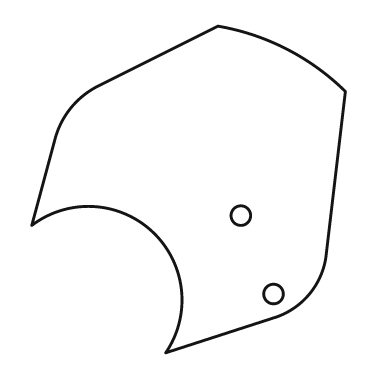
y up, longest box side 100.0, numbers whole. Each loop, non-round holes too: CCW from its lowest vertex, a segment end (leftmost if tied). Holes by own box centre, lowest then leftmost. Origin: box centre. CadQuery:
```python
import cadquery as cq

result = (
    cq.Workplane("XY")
    .moveTo(-7.0, -50.0)
    .lineTo(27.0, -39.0)
    .threePointArc((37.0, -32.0), (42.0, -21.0))
    .lineTo(48.0, 30.0)
    .threePointArc((30.0, 43.0), (9.0, 50.0))
    .lineTo(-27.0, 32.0)
    .threePointArc((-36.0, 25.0), (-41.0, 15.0))
    .lineTo(-48.0, -11.0)
    .threePointArc((-11.0, -13.0), (-7.0, -50.0))
    .close()
    .moveTo(26.0, -32.0)
    .circle(3.0)
    .moveTo(16.0, -8.0)
    .circle(3.0)
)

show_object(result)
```